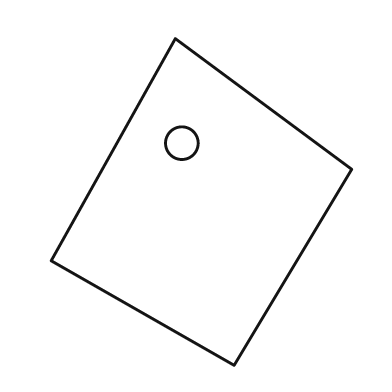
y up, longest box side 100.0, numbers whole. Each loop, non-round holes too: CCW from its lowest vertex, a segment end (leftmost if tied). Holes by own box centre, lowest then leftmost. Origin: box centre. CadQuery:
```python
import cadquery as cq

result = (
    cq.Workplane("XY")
    .moveTo(10.0, -50.0)
    .lineTo(46.0, 10.0)
    .lineTo(-8.0, 50.0)
    .lineTo(-46.0, -18.0)
    .close()
    .moveTo(-6.0, 18.0)
    .circle(5.0)
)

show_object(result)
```